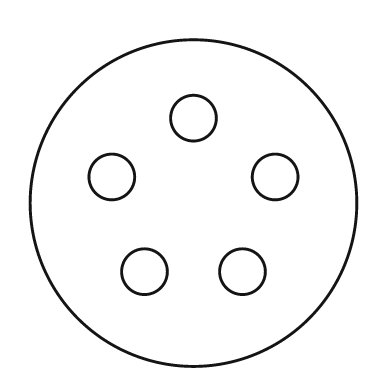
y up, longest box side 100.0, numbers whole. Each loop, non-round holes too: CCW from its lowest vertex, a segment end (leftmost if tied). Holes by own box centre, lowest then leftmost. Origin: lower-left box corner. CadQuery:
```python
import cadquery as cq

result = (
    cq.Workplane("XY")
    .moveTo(50.0, 50.0)
    .circle(50.0)
    .moveTo(35.0, 29.0)
    .circle(7.0)
    .moveTo(65.0, 29.0)
    .circle(7.0)
    .moveTo(25.0, 58.0)
    .circle(7.0)
    .moveTo(75.0, 58.0)
    .circle(7.0)
    .moveTo(50.0, 76.0)
    .circle(7.0)
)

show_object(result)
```